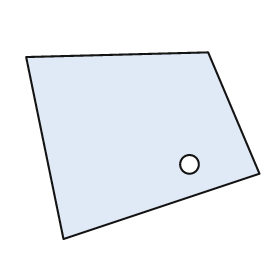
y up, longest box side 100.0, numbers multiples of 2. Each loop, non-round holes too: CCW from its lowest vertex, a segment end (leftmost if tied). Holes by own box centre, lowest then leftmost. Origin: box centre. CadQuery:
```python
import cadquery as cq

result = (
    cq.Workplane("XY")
    .moveTo(-34.0, -40.0)
    .lineTo(50.0, -12.0)
    .lineTo(28.0, 40.0)
    .lineTo(-50.0, 38.0)
    .close()
    .moveTo(20.0, -8.0)
    .circle(4.0)
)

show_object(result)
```